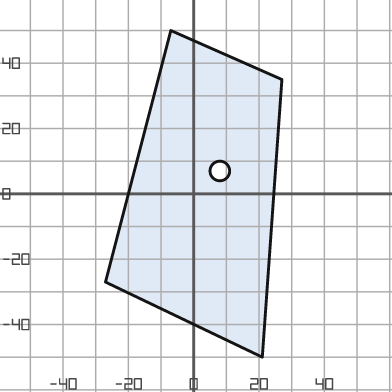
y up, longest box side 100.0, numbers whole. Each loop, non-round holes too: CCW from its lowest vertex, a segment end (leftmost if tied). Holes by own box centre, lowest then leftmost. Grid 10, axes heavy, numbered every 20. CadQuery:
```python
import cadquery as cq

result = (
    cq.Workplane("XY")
    .moveTo(21.0, -50.0)
    .lineTo(27.0, 35.0)
    .lineTo(-7.0, 50.0)
    .lineTo(-27.0, -27.0)
    .close()
    .moveTo(8.0, 7.0)
    .circle(3.0)
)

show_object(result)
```